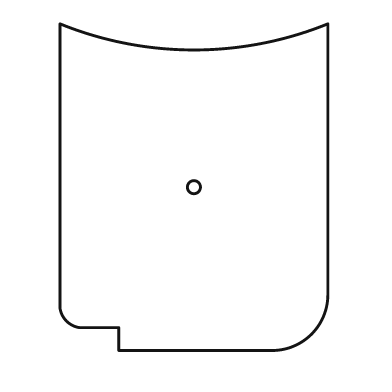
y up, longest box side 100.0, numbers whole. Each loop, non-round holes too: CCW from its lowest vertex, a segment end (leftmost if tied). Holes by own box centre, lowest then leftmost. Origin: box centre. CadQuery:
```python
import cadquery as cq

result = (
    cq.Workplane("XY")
    .moveTo(-23.0, -50.0)
    .lineTo(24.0, -50.0)
    .threePointArc((36.0, -45.0), (41.0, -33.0))
    .lineTo(41.0, 50.0)
    .threePointArc((0.0, 42.0), (-41.0, 50.0))
    .lineTo(-41.0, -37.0)
    .threePointArc((-39.0, -41.0), (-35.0, -43.0))
    .lineTo(-23.0, -43.0)
    .close()
    .moveTo(0.0, 0.0)
    .circle(2.0)
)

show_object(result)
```